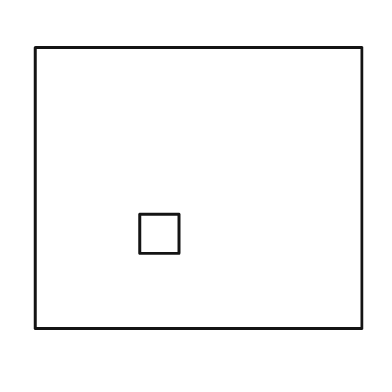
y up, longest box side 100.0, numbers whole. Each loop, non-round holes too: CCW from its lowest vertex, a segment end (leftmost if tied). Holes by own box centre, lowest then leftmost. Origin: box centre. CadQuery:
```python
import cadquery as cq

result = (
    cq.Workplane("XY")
    .moveTo(-50.0, -43.0)
    .lineTo(50.0, -43.0)
    .lineTo(50.0, 43.0)
    .lineTo(-50.0, 43.0)
    .close()
    .moveTo(-18.0, -20.0)
    .lineTo(-6.0, -20.0)
    .lineTo(-6.0, -8.0)
    .lineTo(-18.0, -8.0)
    .close()
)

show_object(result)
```